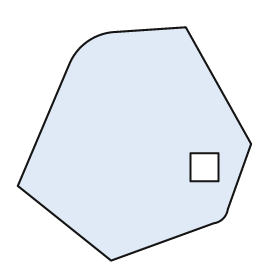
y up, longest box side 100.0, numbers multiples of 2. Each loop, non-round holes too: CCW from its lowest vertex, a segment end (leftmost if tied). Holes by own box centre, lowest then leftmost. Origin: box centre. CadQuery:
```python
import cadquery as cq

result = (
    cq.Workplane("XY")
    .moveTo(-10.0, -50.0)
    .lineTo(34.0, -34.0)
    .threePointArc((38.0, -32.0), (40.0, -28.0))
    .lineTo(50.0, 0.0)
    .lineTo(22.0, 50.0)
    .lineTo(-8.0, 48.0)
    .threePointArc((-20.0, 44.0), (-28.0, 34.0))
    .lineTo(-50.0, -18.0)
    .close()
    .moveTo(24.0, -16.0)
    .lineTo(36.0, -16.0)
    .lineTo(36.0, -4.0)
    .lineTo(24.0, -4.0)
    .close()
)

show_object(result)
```